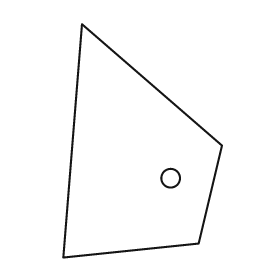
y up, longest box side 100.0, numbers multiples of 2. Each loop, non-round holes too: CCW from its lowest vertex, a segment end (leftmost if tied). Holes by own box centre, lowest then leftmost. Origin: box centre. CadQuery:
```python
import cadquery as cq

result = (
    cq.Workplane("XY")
    .moveTo(-34.0, -50.0)
    .lineTo(24.0, -44.0)
    .lineTo(34.0, -2.0)
    .lineTo(-26.0, 50.0)
    .close()
    .moveTo(12.0, -16.0)
    .circle(4.0)
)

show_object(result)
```